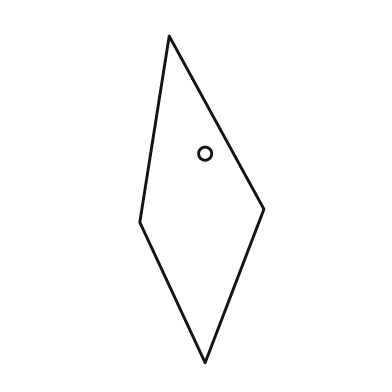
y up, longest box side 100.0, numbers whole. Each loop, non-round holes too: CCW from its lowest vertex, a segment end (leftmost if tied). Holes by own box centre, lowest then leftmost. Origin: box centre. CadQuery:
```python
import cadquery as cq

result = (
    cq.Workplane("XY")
    .moveTo(1.0, -50.0)
    .lineTo(19.0, -3.0)
    .lineTo(-10.0, 50.0)
    .lineTo(-19.0, -7.0)
    .close()
    .moveTo(1.0, 14.0)
    .circle(2.0)
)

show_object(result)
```